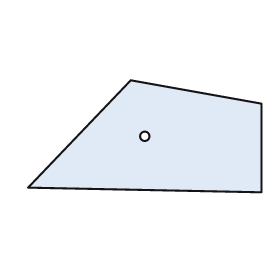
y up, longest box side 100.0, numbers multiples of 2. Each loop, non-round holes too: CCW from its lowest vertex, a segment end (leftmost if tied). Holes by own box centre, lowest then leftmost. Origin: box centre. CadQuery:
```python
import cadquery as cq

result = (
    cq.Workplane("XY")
    .moveTo(50.0, -24.0)
    .lineTo(50.0, 14.0)
    .lineTo(-6.0, 24.0)
    .lineTo(-50.0, -22.0)
    .close()
    .moveTo(0.0, 0.0)
    .circle(2.0)
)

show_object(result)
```